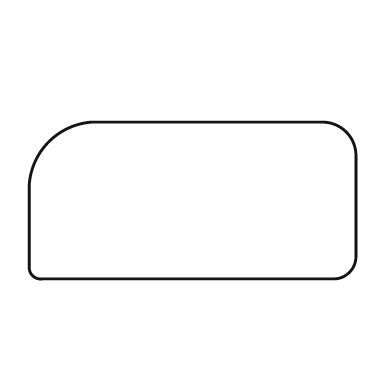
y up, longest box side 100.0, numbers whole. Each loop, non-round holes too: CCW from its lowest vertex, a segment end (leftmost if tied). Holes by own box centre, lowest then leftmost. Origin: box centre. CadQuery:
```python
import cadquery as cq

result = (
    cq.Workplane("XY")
    .moveTo(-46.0, -24.0)
    .lineTo(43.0, -24.0)
    .threePointArc((48.0, -22.0), (50.0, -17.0))
    .lineTo(50.0, 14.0)
    .threePointArc((47.0, 21.0), (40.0, 24.0))
    .lineTo(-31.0, 24.0)
    .threePointArc((-44.0, 18.0), (-50.0, 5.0))
    .lineTo(-50.0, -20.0)
    .threePointArc((-49.0, -23.0), (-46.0, -24.0))
    .close()
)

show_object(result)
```